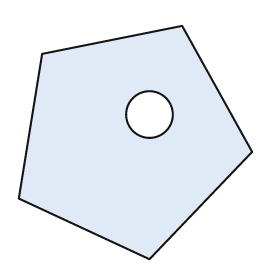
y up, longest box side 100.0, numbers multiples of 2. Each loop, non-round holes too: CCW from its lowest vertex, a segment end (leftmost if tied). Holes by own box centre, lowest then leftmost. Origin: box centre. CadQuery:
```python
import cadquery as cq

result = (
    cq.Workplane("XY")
    .moveTo(6.0, -50.0)
    .lineTo(50.0, -4.0)
    .lineTo(20.0, 50.0)
    .lineTo(-40.0, 38.0)
    .lineTo(-50.0, -24.0)
    .close()
    .moveTo(6.0, 12.0)
    .circle(10.0)
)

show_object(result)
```